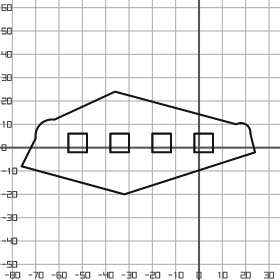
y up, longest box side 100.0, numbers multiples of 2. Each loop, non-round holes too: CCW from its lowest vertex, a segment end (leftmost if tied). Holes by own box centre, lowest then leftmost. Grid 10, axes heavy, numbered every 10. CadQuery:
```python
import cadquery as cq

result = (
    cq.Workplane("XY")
    .moveTo(-32.0, -20.0)
    .lineTo(24.0, -2.0)
    .lineTo(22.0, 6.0)
    .threePointArc((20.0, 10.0), (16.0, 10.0))
    .lineTo(-36.0, 24.0)
    .lineTo(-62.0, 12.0)
    .threePointArc((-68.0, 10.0), (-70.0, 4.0))
    .lineTo(-76.0, -8.0)
    .close()
    .moveTo(-56.0, -2.0)
    .lineTo(-48.0, -2.0)
    .lineTo(-48.0, 6.0)
    .lineTo(-56.0, 6.0)
    .close()
    .moveTo(-38.0, -2.0)
    .lineTo(-30.0, -2.0)
    .lineTo(-30.0, 6.0)
    .lineTo(-38.0, 6.0)
    .close()
    .moveTo(-20.0, -2.0)
    .lineTo(-12.0, -2.0)
    .lineTo(-12.0, 6.0)
    .lineTo(-20.0, 6.0)
    .close()
    .moveTo(-2.0, -2.0)
    .lineTo(6.0, -2.0)
    .lineTo(6.0, 6.0)
    .lineTo(-2.0, 6.0)
    .close()
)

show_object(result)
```